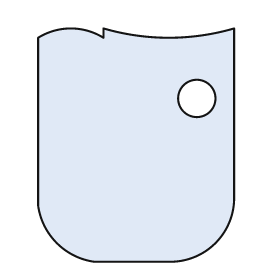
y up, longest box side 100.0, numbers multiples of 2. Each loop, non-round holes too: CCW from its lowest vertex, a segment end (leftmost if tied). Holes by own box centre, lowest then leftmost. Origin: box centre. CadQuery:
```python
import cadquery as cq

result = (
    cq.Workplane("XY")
    .moveTo(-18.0, -50.0)
    .lineTo(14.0, -50.0)
    .threePointArc((34.0, -42.0), (42.0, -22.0))
    .lineTo(42.0, 50.0)
    .threePointArc((14.0, 46.0), (-14.0, 50.0))
    .lineTo(-14.0, 46.0)
    .threePointArc((-28.0, 50.0), (-42.0, 46.0))
    .lineTo(-42.0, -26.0)
    .threePointArc((-34.0, -42.0), (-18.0, -50.0))
    .close()
    .moveTo(26.0, 20.0)
    .circle(8.0)
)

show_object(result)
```